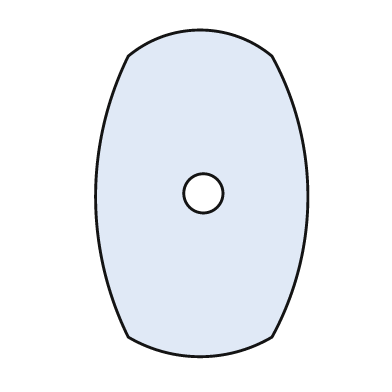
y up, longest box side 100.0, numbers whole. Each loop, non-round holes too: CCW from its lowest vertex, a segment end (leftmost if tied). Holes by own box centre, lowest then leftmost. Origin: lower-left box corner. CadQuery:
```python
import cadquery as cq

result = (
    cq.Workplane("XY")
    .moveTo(10.0, 6.0)
    .threePointArc((32.0, 0.0), (54.0, 6.0))
    .threePointArc((65.0, 49.0), (54.0, 92.0))
    .threePointArc((32.0, 100.0), (10.0, 92.0))
    .threePointArc((0.0, 49.0), (10.0, 6.0))
    .close()
    .moveTo(33.0, 50.0)
    .circle(6.0)
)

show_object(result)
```